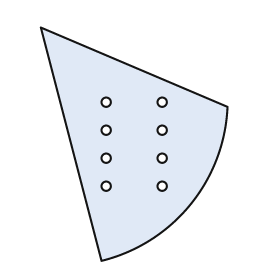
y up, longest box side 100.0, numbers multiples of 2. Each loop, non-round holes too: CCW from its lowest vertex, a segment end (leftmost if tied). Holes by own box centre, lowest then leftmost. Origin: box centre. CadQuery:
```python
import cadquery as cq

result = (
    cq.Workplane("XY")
    .moveTo(-14.0, -50.0)
    .threePointArc((24.0, -26.0), (40.0, 16.0))
    .lineTo(-40.0, 50.0)
    .close()
    .moveTo(-12.0, -18.0)
    .circle(2.0)
    .moveTo(12.0, -18.0)
    .circle(2.0)
    .moveTo(-12.0, -6.0)
    .circle(2.0)
    .moveTo(12.0, -6.0)
    .circle(2.0)
    .moveTo(-12.0, 6.0)
    .circle(2.0)
    .moveTo(12.0, 6.0)
    .circle(2.0)
    .moveTo(-12.0, 18.0)
    .circle(2.0)
    .moveTo(12.0, 18.0)
    .circle(2.0)
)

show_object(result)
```